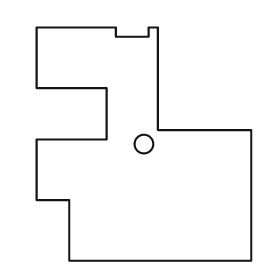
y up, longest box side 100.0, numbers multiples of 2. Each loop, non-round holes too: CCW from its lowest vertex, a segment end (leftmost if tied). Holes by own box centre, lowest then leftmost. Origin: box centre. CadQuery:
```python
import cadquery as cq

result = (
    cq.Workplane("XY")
    .moveTo(-32.0, -50.0)
    .lineTo(46.0, -50.0)
    .lineTo(46.0, 6.0)
    .lineTo(6.0, 6.0)
    .lineTo(6.0, 50.0)
    .lineTo(2.0, 50.0)
    .lineTo(2.0, 46.0)
    .lineTo(-12.0, 46.0)
    .lineTo(-12.0, 50.0)
    .lineTo(-46.0, 50.0)
    .lineTo(-46.0, 24.0)
    .lineTo(-16.0, 24.0)
    .lineTo(-16.0, 2.0)
    .lineTo(-46.0, 2.0)
    .lineTo(-46.0, -24.0)
    .lineTo(-32.0, -24.0)
    .close()
    .moveTo(0.0, 0.0)
    .circle(4.0)
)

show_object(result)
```